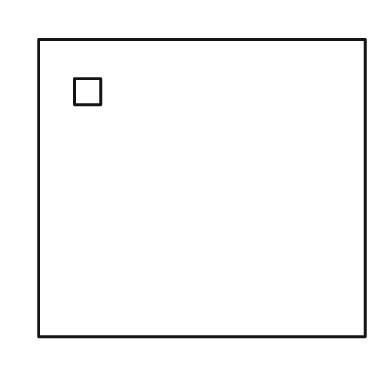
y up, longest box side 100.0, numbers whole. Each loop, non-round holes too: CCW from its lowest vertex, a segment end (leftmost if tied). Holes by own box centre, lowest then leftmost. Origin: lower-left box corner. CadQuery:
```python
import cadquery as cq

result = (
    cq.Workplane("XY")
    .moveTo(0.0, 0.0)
    .lineTo(100.0, 0.0)
    .lineTo(100.0, 91.0)
    .lineTo(0.0, 91.0)
    .close()
    .moveTo(11.0, 71.0)
    .lineTo(19.0, 71.0)
    .lineTo(19.0, 79.0)
    .lineTo(11.0, 79.0)
    .close()
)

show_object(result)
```